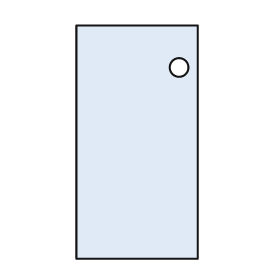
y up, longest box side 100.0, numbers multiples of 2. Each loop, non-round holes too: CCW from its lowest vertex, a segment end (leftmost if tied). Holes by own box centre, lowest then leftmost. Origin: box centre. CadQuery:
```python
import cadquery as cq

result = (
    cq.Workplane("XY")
    .moveTo(-26.0, -50.0)
    .lineTo(26.0, -50.0)
    .lineTo(26.0, 50.0)
    .lineTo(-26.0, 50.0)
    .close()
    .moveTo(18.0, 32.0)
    .circle(4.0)
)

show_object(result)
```